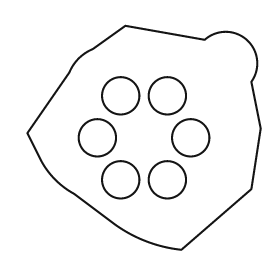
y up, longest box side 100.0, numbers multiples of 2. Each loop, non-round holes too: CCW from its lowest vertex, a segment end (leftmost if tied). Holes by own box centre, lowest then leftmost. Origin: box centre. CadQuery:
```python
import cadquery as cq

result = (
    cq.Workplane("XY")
    .moveTo(16.0, -48.0)
    .lineTo(46.0, -22.0)
    .lineTo(50.0, 4.0)
    .lineTo(46.0, 24.0)
    .threePointArc((44.0, 42.0), (26.0, 42.0))
    .lineTo(-8.0, 48.0)
    .lineTo(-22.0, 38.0)
    .threePointArc((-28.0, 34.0), (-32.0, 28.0))
    .lineTo(-50.0, 2.0)
    .lineTo(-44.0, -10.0)
    .threePointArc((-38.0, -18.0), (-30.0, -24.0))
    .lineTo(-14.0, -36.0)
    .threePointArc((0.0, -44.0), (16.0, -48.0))
    .close()
    .moveTo(-10.0, -18.0)
    .circle(8.0)
    .moveTo(10.0, -18.0)
    .circle(8.0)
    .moveTo(-20.0, 0.0)
    .circle(8.0)
    .moveTo(20.0, 0.0)
    .circle(8.0)
    .moveTo(-10.0, 18.0)
    .circle(8.0)
    .moveTo(10.0, 18.0)
    .circle(8.0)
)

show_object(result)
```